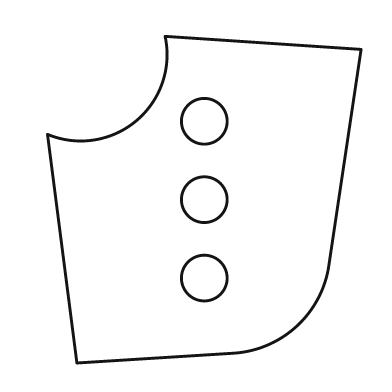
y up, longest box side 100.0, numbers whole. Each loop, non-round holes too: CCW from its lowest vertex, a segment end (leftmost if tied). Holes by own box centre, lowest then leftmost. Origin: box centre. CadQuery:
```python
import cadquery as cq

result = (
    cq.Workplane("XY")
    .moveTo(-39.0, -50.0)
    .lineTo(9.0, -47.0)
    .threePointArc((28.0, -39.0), (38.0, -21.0))
    .lineTo(48.0, 46.0)
    .lineTo(-12.0, 50.0)
    .threePointArc((-21.0, 24.0), (-48.0, 20.0))
    .close()
    .moveTo(0.0, -24.0)
    .circle(7.0)
    .moveTo(0.0, 0.0)
    .circle(7.0)
    .moveTo(0.0, 24.0)
    .circle(7.0)
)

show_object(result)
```